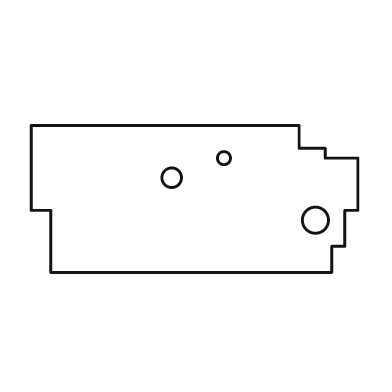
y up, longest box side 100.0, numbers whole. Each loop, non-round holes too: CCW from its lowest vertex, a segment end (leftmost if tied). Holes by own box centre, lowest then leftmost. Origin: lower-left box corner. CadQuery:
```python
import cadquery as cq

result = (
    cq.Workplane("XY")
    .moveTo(6.0, 0.0)
    .lineTo(92.0, 0.0)
    .lineTo(92.0, 8.0)
    .lineTo(96.0, 8.0)
    .lineTo(96.0, 19.0)
    .lineTo(100.0, 19.0)
    .lineTo(100.0, 35.0)
    .lineTo(90.0, 35.0)
    .lineTo(90.0, 38.0)
    .lineTo(82.0, 38.0)
    .lineTo(82.0, 45.0)
    .lineTo(0.0, 45.0)
    .lineTo(0.0, 19.0)
    .lineTo(6.0, 19.0)
    .close()
    .moveTo(87.0, 16.0)
    .circle(4.0)
    .moveTo(43.0, 29.0)
    .circle(3.0)
    .moveTo(59.0, 35.0)
    .circle(2.0)
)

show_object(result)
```